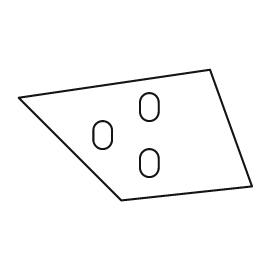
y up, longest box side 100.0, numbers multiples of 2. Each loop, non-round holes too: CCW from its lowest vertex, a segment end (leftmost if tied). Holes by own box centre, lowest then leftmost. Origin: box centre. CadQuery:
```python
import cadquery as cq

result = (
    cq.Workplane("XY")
    .moveTo(-6.0, -28.0)
    .lineTo(50.0, -22.0)
    .lineTo(32.0, 28.0)
    .lineTo(-50.0, 16.0)
    .close()
    .moveTo(2.0, -14.0)
    .threePointArc((6.0, -18.0), (10.0, -14.0))
    .lineTo(10.0, -10.0)
    .threePointArc((6.0, -6.0), (2.0, -10.0))
    .close()
    .moveTo(-18.0, -2.0)
    .threePointArc((-14.0, -6.0), (-10.0, -2.0))
    .lineTo(-10.0, 2.0)
    .threePointArc((-14.0, 6.0), (-18.0, 2.0))
    .close()
    .moveTo(2.0, 10.0)
    .threePointArc((6.0, 6.0), (10.0, 10.0))
    .lineTo(10.0, 14.0)
    .threePointArc((6.0, 18.0), (2.0, 14.0))
    .close()
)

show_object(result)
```